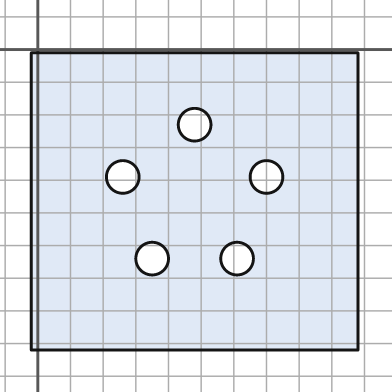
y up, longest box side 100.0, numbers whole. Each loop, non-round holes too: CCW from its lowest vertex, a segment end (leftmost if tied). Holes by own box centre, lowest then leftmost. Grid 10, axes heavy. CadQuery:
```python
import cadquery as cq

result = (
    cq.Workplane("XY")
    .moveTo(-2.0, -92.0)
    .lineTo(98.0, -92.0)
    .lineTo(98.0, -1.0)
    .lineTo(-2.0, -1.0)
    .close()
    .moveTo(35.0, -64.0)
    .circle(5.0)
    .moveTo(61.0, -64.0)
    .circle(5.0)
    .moveTo(26.0, -39.0)
    .circle(5.0)
    .moveTo(70.0, -39.0)
    .circle(5.0)
    .moveTo(48.0, -23.0)
    .circle(5.0)
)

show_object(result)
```